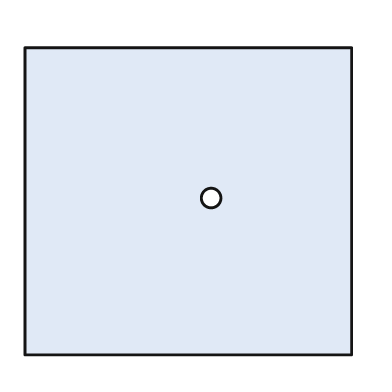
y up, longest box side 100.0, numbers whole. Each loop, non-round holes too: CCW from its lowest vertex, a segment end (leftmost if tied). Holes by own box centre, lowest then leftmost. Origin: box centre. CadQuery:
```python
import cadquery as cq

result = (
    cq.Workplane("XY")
    .moveTo(-50.0, -47.0)
    .lineTo(50.0, -47.0)
    .lineTo(50.0, 47.0)
    .lineTo(-50.0, 47.0)
    .close()
    .moveTo(7.0, 1.0)
    .circle(3.0)
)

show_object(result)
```